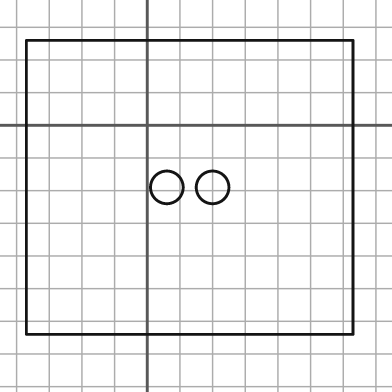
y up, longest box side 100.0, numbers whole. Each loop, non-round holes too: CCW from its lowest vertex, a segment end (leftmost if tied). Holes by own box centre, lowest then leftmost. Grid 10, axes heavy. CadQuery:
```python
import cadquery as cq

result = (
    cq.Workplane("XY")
    .moveTo(-37.0, -64.0)
    .lineTo(63.0, -64.0)
    .lineTo(63.0, 26.0)
    .lineTo(-37.0, 26.0)
    .close()
    .moveTo(6.0, -19.0)
    .circle(5.0)
    .moveTo(20.0, -19.0)
    .circle(5.0)
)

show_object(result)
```